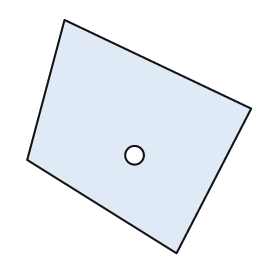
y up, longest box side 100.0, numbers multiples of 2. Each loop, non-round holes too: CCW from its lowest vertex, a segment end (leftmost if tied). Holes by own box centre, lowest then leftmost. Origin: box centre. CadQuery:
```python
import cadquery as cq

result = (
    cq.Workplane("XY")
    .moveTo(16.0, -50.0)
    .lineTo(48.0, 12.0)
    .lineTo(-32.0, 50.0)
    .lineTo(-48.0, -10.0)
    .close()
    .moveTo(-2.0, -8.0)
    .circle(4.0)
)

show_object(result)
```